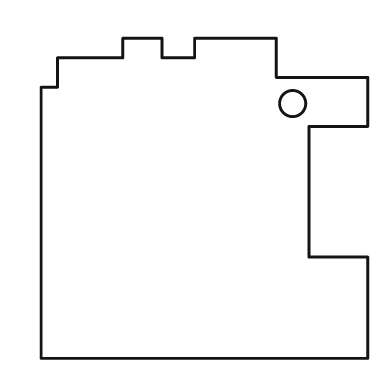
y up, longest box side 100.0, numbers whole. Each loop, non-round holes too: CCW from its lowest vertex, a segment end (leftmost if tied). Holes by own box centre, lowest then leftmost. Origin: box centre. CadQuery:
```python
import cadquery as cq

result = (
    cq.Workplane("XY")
    .moveTo(-50.0, -49.0)
    .lineTo(50.0, -49.0)
    .lineTo(50.0, -18.0)
    .lineTo(32.0, -18.0)
    .lineTo(32.0, 22.0)
    .lineTo(50.0, 22.0)
    .lineTo(50.0, 37.0)
    .lineTo(22.0, 37.0)
    .lineTo(22.0, 49.0)
    .lineTo(-3.0, 49.0)
    .lineTo(-3.0, 43.0)
    .lineTo(-13.0, 43.0)
    .lineTo(-13.0, 49.0)
    .lineTo(-25.0, 49.0)
    .lineTo(-25.0, 43.0)
    .lineTo(-45.0, 43.0)
    .lineTo(-45.0, 34.0)
    .lineTo(-50.0, 34.0)
    .close()
    .moveTo(27.0, 29.0)
    .circle(4.0)
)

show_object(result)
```